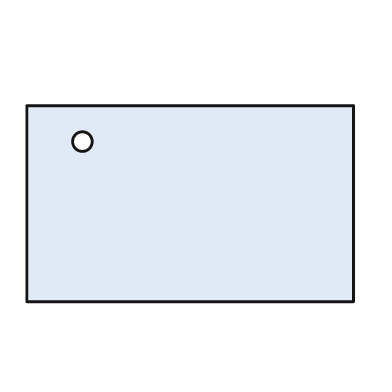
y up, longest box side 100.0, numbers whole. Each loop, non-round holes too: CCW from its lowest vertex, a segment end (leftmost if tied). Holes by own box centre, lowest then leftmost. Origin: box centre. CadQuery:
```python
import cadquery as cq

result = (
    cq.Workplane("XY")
    .moveTo(-50.0, -30.0)
    .lineTo(50.0, -30.0)
    .lineTo(50.0, 30.0)
    .lineTo(-50.0, 30.0)
    .close()
    .moveTo(-33.0, 19.0)
    .circle(3.0)
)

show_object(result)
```